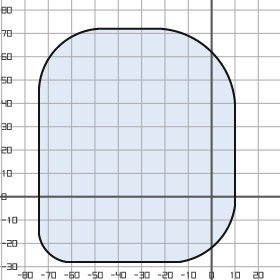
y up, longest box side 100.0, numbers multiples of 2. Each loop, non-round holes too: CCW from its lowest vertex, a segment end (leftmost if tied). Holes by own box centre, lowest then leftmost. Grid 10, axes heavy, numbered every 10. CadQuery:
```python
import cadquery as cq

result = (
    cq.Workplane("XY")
    .moveTo(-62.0, -28.0)
    .lineTo(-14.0, -28.0)
    .threePointArc((2.0, -20.0), (10.0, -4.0))
    .lineTo(10.0, 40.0)
    .threePointArc((0.0, 62.0), (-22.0, 72.0))
    .lineTo(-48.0, 72.0)
    .threePointArc((-66.0, 64.0), (-74.0, 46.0))
    .lineTo(-74.0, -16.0)
    .threePointArc((-70.0, -24.0), (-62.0, -28.0))
    .close()
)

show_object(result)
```